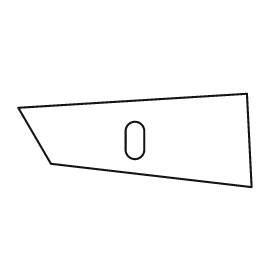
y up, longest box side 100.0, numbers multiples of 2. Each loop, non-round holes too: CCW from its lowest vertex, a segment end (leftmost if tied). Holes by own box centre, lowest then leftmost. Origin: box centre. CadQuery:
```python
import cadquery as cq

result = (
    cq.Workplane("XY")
    .moveTo(50.0, -20.0)
    .lineTo(48.0, 20.0)
    .lineTo(-50.0, 14.0)
    .lineTo(-36.0, -10.0)
    .close()
    .moveTo(-4.0, -4.0)
    .threePointArc((0.0, -8.0), (4.0, -4.0))
    .lineTo(4.0, 4.0)
    .threePointArc((0.0, 8.0), (-4.0, 4.0))
    .close()
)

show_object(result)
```